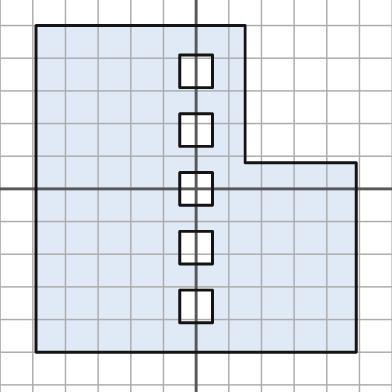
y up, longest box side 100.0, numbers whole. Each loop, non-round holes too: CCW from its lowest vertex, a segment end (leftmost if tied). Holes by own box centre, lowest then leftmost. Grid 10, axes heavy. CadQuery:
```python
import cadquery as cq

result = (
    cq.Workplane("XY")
    .moveTo(-49.0, -50.0)
    .lineTo(49.0, -50.0)
    .lineTo(49.0, 8.0)
    .lineTo(15.0, 8.0)
    .lineTo(15.0, 50.0)
    .lineTo(-49.0, 50.0)
    .close()
    .moveTo(-5.0, -41.0)
    .lineTo(5.0, -41.0)
    .lineTo(5.0, -31.0)
    .lineTo(-5.0, -31.0)
    .close()
    .moveTo(-5.0, -23.0)
    .lineTo(5.0, -23.0)
    .lineTo(5.0, -13.0)
    .lineTo(-5.0, -13.0)
    .close()
    .moveTo(-5.0, -5.0)
    .lineTo(5.0, -5.0)
    .lineTo(5.0, 5.0)
    .lineTo(-5.0, 5.0)
    .close()
    .moveTo(-5.0, 13.0)
    .lineTo(5.0, 13.0)
    .lineTo(5.0, 23.0)
    .lineTo(-5.0, 23.0)
    .close()
    .moveTo(-5.0, 31.0)
    .lineTo(5.0, 31.0)
    .lineTo(5.0, 41.0)
    .lineTo(-5.0, 41.0)
    .close()
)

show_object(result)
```